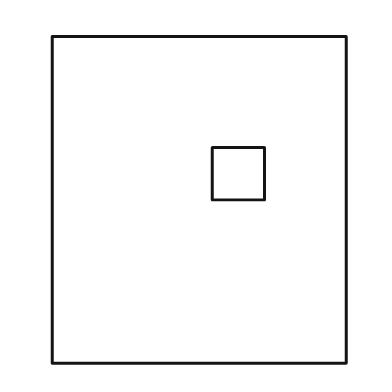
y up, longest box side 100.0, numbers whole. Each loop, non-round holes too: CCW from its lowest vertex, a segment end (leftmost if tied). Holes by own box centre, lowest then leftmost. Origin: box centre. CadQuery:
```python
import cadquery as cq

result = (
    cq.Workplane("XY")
    .moveTo(-45.0, -50.0)
    .lineTo(45.0, -50.0)
    .lineTo(45.0, 50.0)
    .lineTo(-45.0, 50.0)
    .close()
    .moveTo(4.0, 0.0)
    .lineTo(20.0, 0.0)
    .lineTo(20.0, 16.0)
    .lineTo(4.0, 16.0)
    .close()
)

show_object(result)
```